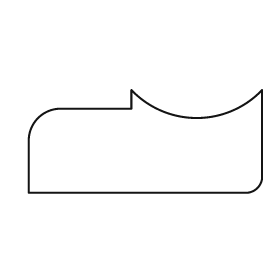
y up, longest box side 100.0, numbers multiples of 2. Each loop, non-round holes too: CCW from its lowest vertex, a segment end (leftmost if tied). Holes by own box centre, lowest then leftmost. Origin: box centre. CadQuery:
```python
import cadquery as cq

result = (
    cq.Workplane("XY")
    .moveTo(-50.0, -22.0)
    .lineTo(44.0, -22.0)
    .threePointArc((48.0, -20.0), (50.0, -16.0))
    .lineTo(50.0, 22.0)
    .threePointArc((22.0, 10.0), (-6.0, 22.0))
    .lineTo(-6.0, 14.0)
    .lineTo(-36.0, 14.0)
    .threePointArc((-46.0, 10.0), (-50.0, 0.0))
    .close()
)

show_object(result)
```